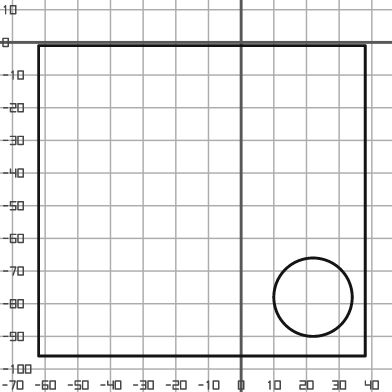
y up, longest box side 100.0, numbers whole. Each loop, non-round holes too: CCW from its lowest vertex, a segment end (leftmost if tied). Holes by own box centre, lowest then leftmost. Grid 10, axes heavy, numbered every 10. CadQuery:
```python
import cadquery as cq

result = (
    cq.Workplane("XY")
    .moveTo(-62.0, -96.0)
    .lineTo(38.0, -96.0)
    .lineTo(38.0, -1.0)
    .lineTo(-62.0, -1.0)
    .close()
    .moveTo(22.0, -78.0)
    .circle(12.0)
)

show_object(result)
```